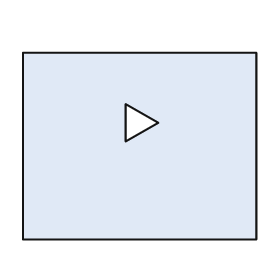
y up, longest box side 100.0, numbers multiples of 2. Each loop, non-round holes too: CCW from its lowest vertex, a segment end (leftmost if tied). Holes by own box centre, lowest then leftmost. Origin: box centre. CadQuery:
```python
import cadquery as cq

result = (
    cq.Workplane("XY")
    .moveTo(-50.0, -40.0)
    .lineTo(50.0, -40.0)
    .lineTo(50.0, 40.0)
    .lineTo(-50.0, 40.0)
    .close()
    .moveTo(-6.0, 2.0)
    .lineTo(8.0, 10.0)
    .lineTo(-6.0, 18.0)
    .close()
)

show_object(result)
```